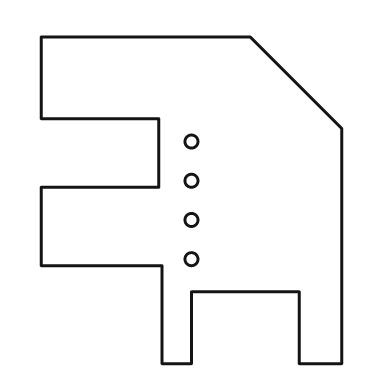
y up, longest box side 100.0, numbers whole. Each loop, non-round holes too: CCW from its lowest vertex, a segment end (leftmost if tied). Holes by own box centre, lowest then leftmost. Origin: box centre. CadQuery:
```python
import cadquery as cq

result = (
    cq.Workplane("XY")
    .moveTo(-9.0, -50.0)
    .lineTo(0.0, -50.0)
    .lineTo(0.0, -28.0)
    .lineTo(33.0, -28.0)
    .lineTo(33.0, -50.0)
    .lineTo(46.0, -50.0)
    .lineTo(46.0, 22.0)
    .lineTo(18.0, 50.0)
    .lineTo(-46.0, 50.0)
    .lineTo(-46.0, 25.0)
    .lineTo(-10.0, 25.0)
    .lineTo(-10.0, 4.0)
    .lineTo(-46.0, 4.0)
    .lineTo(-46.0, -20.0)
    .lineTo(-9.0, -20.0)
    .close()
    .moveTo(0.0, -18.0)
    .circle(2.0)
    .moveTo(0.0, -6.0)
    .circle(2.0)
    .moveTo(0.0, 6.0)
    .circle(2.0)
    .moveTo(0.0, 18.0)
    .circle(2.0)
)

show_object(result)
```